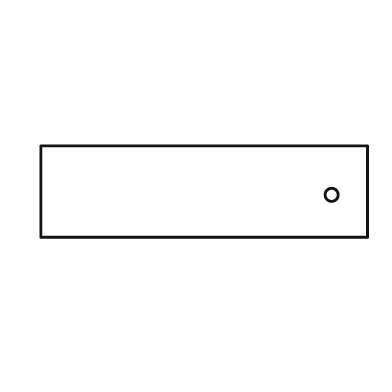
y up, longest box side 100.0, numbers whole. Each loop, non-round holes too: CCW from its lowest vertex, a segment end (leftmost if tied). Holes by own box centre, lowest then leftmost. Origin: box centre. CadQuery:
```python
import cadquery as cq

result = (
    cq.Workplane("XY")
    .moveTo(-50.0, -14.0)
    .lineTo(50.0, -14.0)
    .lineTo(50.0, 14.0)
    .lineTo(-50.0, 14.0)
    .close()
    .moveTo(39.0, -1.0)
    .circle(2.0)
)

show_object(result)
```